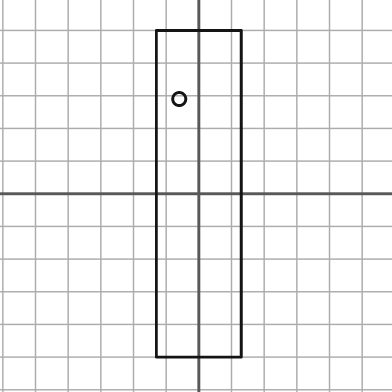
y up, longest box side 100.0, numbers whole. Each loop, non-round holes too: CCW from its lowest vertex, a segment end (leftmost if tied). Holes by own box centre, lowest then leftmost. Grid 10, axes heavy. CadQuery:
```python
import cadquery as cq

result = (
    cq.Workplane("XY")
    .moveTo(-13.0, -50.0)
    .lineTo(13.0, -50.0)
    .lineTo(13.0, 50.0)
    .lineTo(-13.0, 50.0)
    .close()
    .moveTo(-6.0, 29.0)
    .circle(2.0)
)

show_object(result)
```